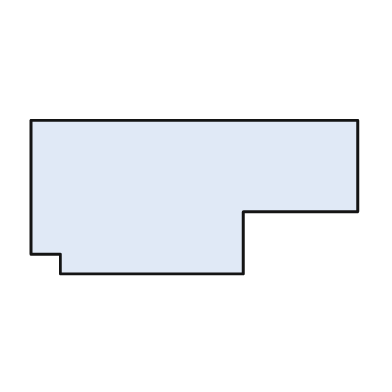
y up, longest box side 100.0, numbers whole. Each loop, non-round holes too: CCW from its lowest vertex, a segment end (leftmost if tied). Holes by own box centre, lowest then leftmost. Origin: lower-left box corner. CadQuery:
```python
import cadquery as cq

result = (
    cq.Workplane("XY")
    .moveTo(9.0, 0.0)
    .lineTo(65.0, 0.0)
    .lineTo(65.0, 19.0)
    .lineTo(100.0, 19.0)
    .lineTo(100.0, 47.0)
    .lineTo(0.0, 47.0)
    .lineTo(0.0, 6.0)
    .lineTo(9.0, 6.0)
    .close()
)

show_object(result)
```